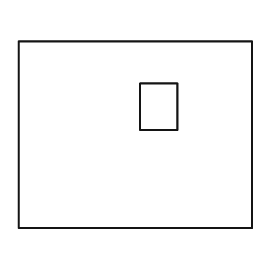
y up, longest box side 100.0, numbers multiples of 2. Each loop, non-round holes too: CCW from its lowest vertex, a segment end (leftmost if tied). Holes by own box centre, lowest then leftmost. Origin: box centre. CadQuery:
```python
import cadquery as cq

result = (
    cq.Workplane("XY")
    .moveTo(-50.0, -40.0)
    .lineTo(50.0, -40.0)
    .lineTo(50.0, 40.0)
    .lineTo(-50.0, 40.0)
    .close()
    .moveTo(2.0, 2.0)
    .lineTo(18.0, 2.0)
    .lineTo(18.0, 22.0)
    .lineTo(2.0, 22.0)
    .close()
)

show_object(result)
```